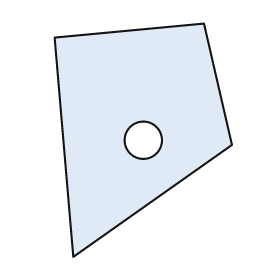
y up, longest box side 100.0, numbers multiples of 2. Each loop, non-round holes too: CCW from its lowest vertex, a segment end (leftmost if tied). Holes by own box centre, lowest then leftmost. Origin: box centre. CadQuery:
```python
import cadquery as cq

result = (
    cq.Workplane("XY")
    .moveTo(-30.0, -50.0)
    .lineTo(38.0, -2.0)
    .lineTo(26.0, 50.0)
    .lineTo(-38.0, 44.0)
    .close()
    .moveTo(0.0, 0.0)
    .circle(8.0)
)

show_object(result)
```